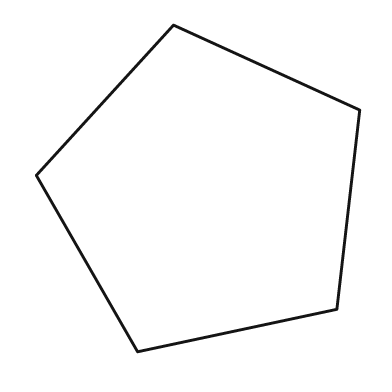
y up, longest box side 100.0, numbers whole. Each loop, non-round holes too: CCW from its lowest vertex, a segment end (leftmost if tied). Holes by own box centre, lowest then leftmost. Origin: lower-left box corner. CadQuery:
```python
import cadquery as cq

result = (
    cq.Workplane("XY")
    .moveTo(31.0, 0.0)
    .lineTo(92.0, 13.0)
    .lineTo(99.0, 74.0)
    .lineTo(42.0, 100.0)
    .lineTo(0.0, 54.0)
    .close()
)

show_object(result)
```